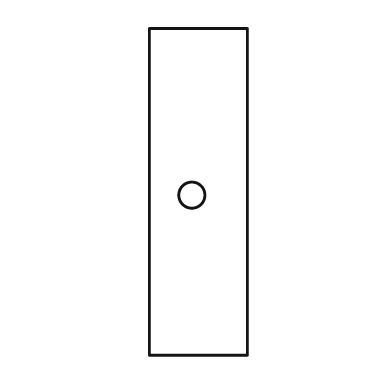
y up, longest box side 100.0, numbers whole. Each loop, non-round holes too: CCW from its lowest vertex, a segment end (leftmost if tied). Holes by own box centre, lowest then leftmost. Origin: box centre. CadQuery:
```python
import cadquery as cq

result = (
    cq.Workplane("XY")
    .moveTo(-15.0, -50.0)
    .lineTo(15.0, -50.0)
    .lineTo(15.0, 50.0)
    .lineTo(-15.0, 50.0)
    .close()
    .moveTo(-2.0, -1.0)
    .circle(4.0)
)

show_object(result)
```